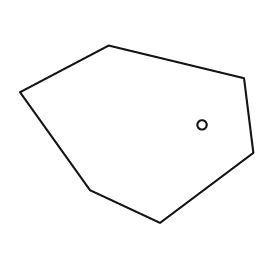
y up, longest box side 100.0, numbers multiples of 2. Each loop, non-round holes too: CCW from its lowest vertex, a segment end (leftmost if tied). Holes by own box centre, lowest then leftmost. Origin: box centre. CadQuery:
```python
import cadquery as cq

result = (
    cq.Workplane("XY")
    .moveTo(10.0, -38.0)
    .lineTo(50.0, -8.0)
    .lineTo(46.0, 24.0)
    .lineTo(-12.0, 38.0)
    .lineTo(-50.0, 18.0)
    .lineTo(-20.0, -24.0)
    .close()
    .moveTo(28.0, 4.0)
    .circle(2.0)
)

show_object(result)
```